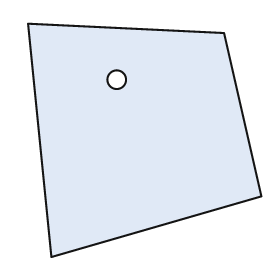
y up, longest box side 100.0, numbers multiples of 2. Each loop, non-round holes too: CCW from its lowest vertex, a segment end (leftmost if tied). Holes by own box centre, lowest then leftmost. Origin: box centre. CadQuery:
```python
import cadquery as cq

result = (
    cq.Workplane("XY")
    .moveTo(-40.0, -50.0)
    .lineTo(50.0, -24.0)
    .lineTo(34.0, 46.0)
    .lineTo(-50.0, 50.0)
    .close()
    .moveTo(-12.0, 26.0)
    .circle(4.0)
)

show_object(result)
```